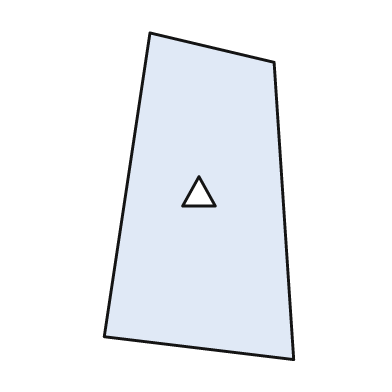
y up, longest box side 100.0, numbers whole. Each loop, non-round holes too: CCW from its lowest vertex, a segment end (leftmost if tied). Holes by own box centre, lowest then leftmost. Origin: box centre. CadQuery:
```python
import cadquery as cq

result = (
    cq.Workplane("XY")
    .moveTo(29.0, -50.0)
    .lineTo(23.0, 41.0)
    .lineTo(-15.0, 50.0)
    .lineTo(-29.0, -43.0)
    .close()
    .moveTo(-5.0, -3.0)
    .lineTo(5.0, -3.0)
    .lineTo(0.0, 6.0)
    .close()
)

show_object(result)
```